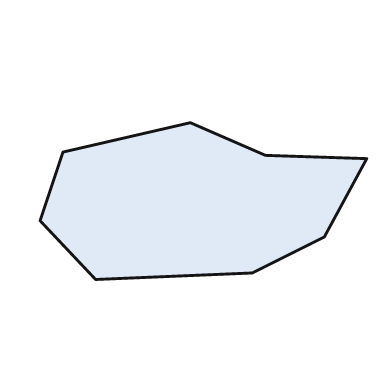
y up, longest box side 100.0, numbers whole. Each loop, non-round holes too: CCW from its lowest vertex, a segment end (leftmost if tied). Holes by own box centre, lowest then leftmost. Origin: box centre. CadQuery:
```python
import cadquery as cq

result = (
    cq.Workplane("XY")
    .moveTo(-33.0, -24.0)
    .lineTo(15.0, -22.0)
    .lineTo(37.0, -11.0)
    .lineTo(50.0, 13.0)
    .lineTo(19.0, 14.0)
    .lineTo(-4.0, 24.0)
    .lineTo(-43.0, 15.0)
    .lineTo(-50.0, -6.0)
    .close()
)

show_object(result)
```